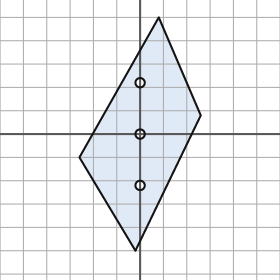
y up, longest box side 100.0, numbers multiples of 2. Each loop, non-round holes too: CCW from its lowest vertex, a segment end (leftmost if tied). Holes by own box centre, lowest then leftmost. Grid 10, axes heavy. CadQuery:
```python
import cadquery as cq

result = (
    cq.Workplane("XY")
    .moveTo(-2.0, -50.0)
    .lineTo(26.0, 8.0)
    .lineTo(8.0, 50.0)
    .lineTo(-26.0, -10.0)
    .close()
    .moveTo(0.0, -22.0)
    .circle(2.0)
    .moveTo(0.0, 0.0)
    .circle(2.0)
    .moveTo(0.0, 22.0)
    .circle(2.0)
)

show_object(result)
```